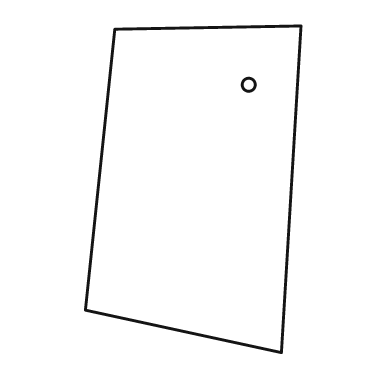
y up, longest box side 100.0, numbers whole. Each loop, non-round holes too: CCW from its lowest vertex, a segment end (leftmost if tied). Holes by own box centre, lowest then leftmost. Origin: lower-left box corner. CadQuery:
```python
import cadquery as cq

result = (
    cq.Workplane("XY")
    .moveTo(60.0, 0.0)
    .lineTo(66.0, 100.0)
    .lineTo(9.0, 99.0)
    .lineTo(0.0, 13.0)
    .close()
    .moveTo(50.0, 82.0)
    .circle(2.0)
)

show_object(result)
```